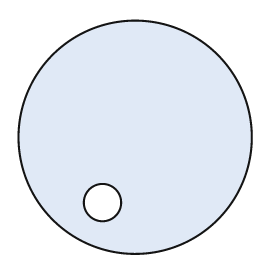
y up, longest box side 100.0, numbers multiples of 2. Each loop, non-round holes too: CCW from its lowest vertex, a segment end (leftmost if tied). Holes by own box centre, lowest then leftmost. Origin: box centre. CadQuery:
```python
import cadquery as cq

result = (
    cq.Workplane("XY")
    .moveTo(0.0, 0.0)
    .circle(50.0)
    .moveTo(-14.0, -28.0)
    .circle(8.0)
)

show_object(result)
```